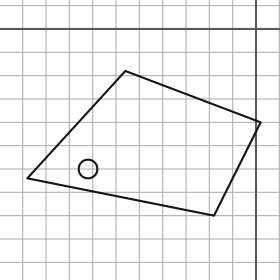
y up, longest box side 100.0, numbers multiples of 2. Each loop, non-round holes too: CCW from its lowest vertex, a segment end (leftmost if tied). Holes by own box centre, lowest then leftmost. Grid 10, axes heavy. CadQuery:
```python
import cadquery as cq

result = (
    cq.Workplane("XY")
    .moveTo(-18.0, -80.0)
    .lineTo(2.0, -40.0)
    .lineTo(-56.0, -18.0)
    .lineTo(-98.0, -64.0)
    .close()
    .moveTo(-72.0, -60.0)
    .circle(4.0)
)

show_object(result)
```